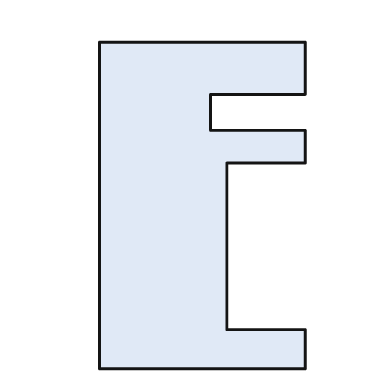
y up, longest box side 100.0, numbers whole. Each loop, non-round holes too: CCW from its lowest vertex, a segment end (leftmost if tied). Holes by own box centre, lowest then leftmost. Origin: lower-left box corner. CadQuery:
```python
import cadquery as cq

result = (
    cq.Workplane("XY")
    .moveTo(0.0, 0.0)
    .lineTo(63.0, 0.0)
    .lineTo(63.0, 12.0)
    .lineTo(39.0, 12.0)
    .lineTo(39.0, 63.0)
    .lineTo(63.0, 63.0)
    .lineTo(63.0, 73.0)
    .lineTo(34.0, 73.0)
    .lineTo(34.0, 84.0)
    .lineTo(63.0, 84.0)
    .lineTo(63.0, 100.0)
    .lineTo(0.0, 100.0)
    .close()
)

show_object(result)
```